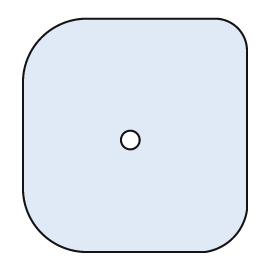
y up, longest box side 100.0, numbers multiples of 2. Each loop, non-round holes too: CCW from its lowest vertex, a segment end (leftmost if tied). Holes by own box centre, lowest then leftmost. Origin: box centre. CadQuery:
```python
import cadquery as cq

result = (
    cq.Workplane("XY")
    .moveTo(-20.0, -50.0)
    .lineTo(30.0, -50.0)
    .threePointArc((42.0, -44.0), (48.0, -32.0))
    .lineTo(48.0, 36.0)
    .threePointArc((44.0, 46.0), (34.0, 50.0))
    .lineTo(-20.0, 50.0)
    .threePointArc((-40.0, 42.0), (-48.0, 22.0))
    .lineTo(-48.0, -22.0)
    .threePointArc((-40.0, -42.0), (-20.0, -50.0))
    .close()
    .moveTo(-2.0, -2.0)
    .circle(4.0)
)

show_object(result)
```